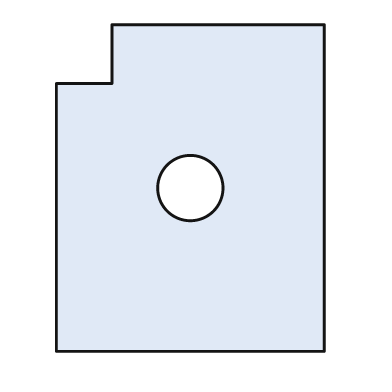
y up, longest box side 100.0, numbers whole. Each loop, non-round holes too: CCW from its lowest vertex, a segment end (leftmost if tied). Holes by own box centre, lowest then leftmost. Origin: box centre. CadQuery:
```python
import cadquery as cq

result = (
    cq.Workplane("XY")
    .moveTo(-41.0, -50.0)
    .lineTo(41.0, -50.0)
    .lineTo(41.0, 50.0)
    .lineTo(-24.0, 50.0)
    .lineTo(-24.0, 32.0)
    .lineTo(-41.0, 32.0)
    .close()
    .moveTo(0.0, 0.0)
    .circle(10.0)
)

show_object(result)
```